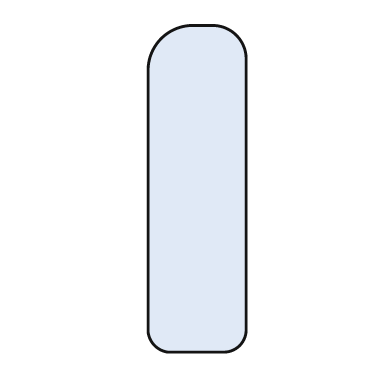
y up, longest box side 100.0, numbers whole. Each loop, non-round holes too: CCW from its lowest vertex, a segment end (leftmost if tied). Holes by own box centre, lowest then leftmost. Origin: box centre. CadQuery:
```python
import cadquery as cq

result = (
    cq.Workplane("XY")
    .moveTo(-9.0, -50.0)
    .lineTo(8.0, -50.0)
    .threePointArc((13.0, -48.0), (15.0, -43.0))
    .lineTo(15.0, 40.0)
    .threePointArc((12.0, 47.0), (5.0, 50.0))
    .lineTo(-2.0, 50.0)
    .threePointArc((-11.0, 46.0), (-15.0, 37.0))
    .lineTo(-15.0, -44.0)
    .threePointArc((-13.0, -48.0), (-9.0, -50.0))
    .close()
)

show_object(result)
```